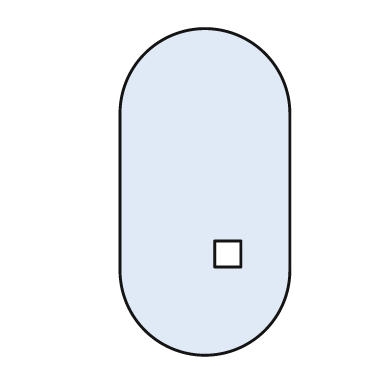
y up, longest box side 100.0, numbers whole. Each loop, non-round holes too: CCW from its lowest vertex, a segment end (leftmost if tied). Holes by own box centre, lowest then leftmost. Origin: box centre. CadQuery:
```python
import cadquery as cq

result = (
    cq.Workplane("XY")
    .moveTo(-26.0, -24.0)
    .threePointArc((0.0, -50.0), (26.0, -24.0))
    .lineTo(26.0, 24.0)
    .threePointArc((0.0, 50.0), (-26.0, 24.0))
    .close()
    .moveTo(3.0, -23.0)
    .lineTo(11.0, -23.0)
    .lineTo(11.0, -15.0)
    .lineTo(3.0, -15.0)
    .close()
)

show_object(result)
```